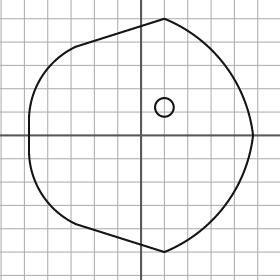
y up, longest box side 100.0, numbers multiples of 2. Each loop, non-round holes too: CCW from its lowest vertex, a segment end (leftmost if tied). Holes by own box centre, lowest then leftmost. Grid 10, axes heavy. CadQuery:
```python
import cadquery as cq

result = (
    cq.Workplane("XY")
    .moveTo(10.0, -50.0)
    .threePointArc((36.0, -30.0), (48.0, 0.0))
    .threePointArc((36.0, 30.0), (10.0, 50.0))
    .lineTo(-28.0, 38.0)
    .threePointArc((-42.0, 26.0), (-48.0, 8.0))
    .lineTo(-48.0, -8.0)
    .threePointArc((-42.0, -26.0), (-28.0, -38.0))
    .close()
    .moveTo(10.0, 12.0)
    .circle(4.0)
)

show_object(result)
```